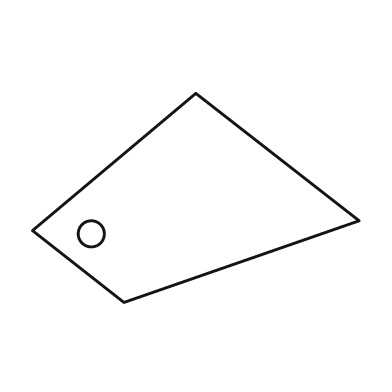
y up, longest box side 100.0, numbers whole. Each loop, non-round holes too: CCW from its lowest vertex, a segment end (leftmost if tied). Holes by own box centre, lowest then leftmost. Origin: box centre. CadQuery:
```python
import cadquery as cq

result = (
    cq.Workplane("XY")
    .moveTo(-22.0, -32.0)
    .lineTo(50.0, -7.0)
    .lineTo(0.0, 32.0)
    .lineTo(-50.0, -10.0)
    .close()
    .moveTo(-32.0, -11.0)
    .circle(4.0)
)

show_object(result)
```